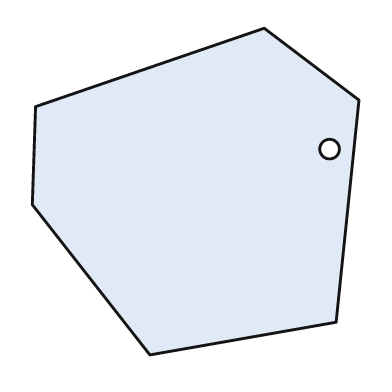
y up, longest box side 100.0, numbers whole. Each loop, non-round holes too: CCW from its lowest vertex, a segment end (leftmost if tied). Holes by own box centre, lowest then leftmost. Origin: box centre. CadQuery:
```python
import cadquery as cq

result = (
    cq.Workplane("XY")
    .moveTo(-14.0, -50.0)
    .lineTo(43.0, -40.0)
    .lineTo(50.0, 28.0)
    .lineTo(21.0, 50.0)
    .lineTo(-49.0, 26.0)
    .lineTo(-50.0, -4.0)
    .close()
    .moveTo(41.0, 13.0)
    .circle(3.0)
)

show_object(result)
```